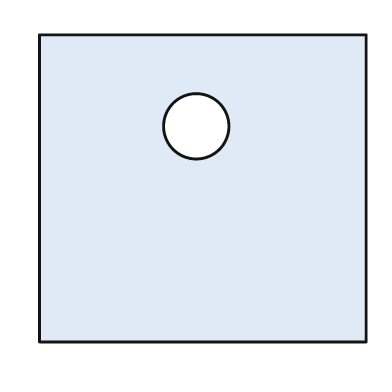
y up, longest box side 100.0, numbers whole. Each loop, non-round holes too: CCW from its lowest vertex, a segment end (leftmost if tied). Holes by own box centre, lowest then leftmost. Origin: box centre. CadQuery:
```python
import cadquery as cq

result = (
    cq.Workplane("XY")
    .moveTo(-50.0, -47.0)
    .lineTo(50.0, -47.0)
    .lineTo(50.0, 47.0)
    .lineTo(-50.0, 47.0)
    .close()
    .moveTo(-2.0, 19.0)
    .circle(10.0)
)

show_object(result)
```